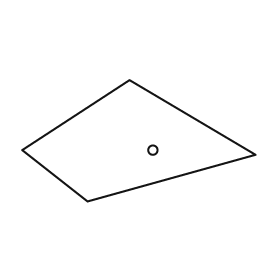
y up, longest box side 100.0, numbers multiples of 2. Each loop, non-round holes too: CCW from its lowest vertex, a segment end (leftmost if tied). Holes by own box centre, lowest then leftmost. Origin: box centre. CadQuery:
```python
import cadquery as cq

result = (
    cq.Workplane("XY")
    .moveTo(-22.0, -26.0)
    .lineTo(50.0, -6.0)
    .lineTo(-4.0, 26.0)
    .lineTo(-50.0, -4.0)
    .close()
    .moveTo(6.0, -4.0)
    .circle(2.0)
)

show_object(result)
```